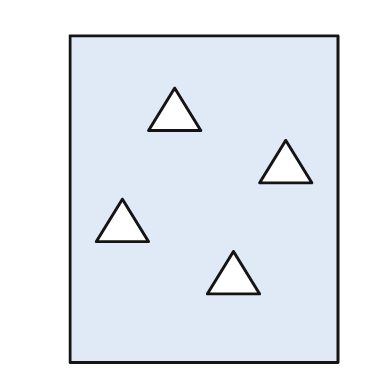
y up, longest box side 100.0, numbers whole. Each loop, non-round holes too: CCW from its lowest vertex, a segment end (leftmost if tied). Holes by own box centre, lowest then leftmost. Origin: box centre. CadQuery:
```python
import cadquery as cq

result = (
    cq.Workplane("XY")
    .moveTo(-41.0, -50.0)
    .lineTo(41.0, -50.0)
    .lineTo(41.0, 50.0)
    .lineTo(-41.0, 50.0)
    .close()
    .moveTo(1.0, -29.0)
    .lineTo(17.0, -29.0)
    .lineTo(9.0, -16.0)
    .close()
    .moveTo(-33.0, -13.0)
    .lineTo(-17.0, -13.0)
    .lineTo(-25.0, 0.0)
    .close()
    .moveTo(17.0, 5.0)
    .lineTo(33.0, 5.0)
    .lineTo(25.0, 18.0)
    .close()
    .moveTo(-17.0, 21.0)
    .lineTo(-1.0, 21.0)
    .lineTo(-9.0, 34.0)
    .close()
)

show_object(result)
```